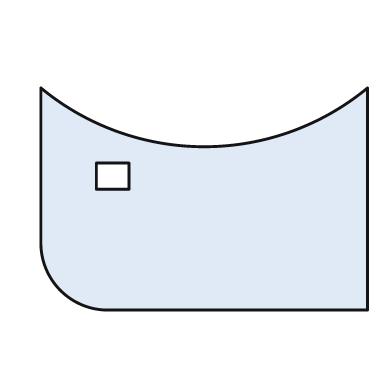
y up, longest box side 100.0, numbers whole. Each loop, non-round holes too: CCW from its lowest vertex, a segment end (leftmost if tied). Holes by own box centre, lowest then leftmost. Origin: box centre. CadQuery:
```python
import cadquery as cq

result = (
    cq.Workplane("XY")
    .moveTo(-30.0, -34.0)
    .lineTo(50.0, -34.0)
    .lineTo(50.0, 34.0)
    .threePointArc((0.0, 16.0), (-50.0, 34.0))
    .lineTo(-50.0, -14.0)
    .threePointArc((-44.0, -28.0), (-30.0, -34.0))
    .close()
    .moveTo(-33.0, 3.0)
    .lineTo(-23.0, 3.0)
    .lineTo(-23.0, 11.0)
    .lineTo(-33.0, 11.0)
    .close()
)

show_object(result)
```